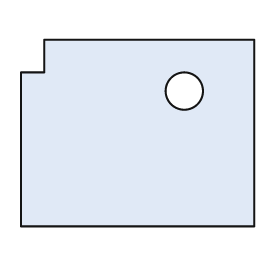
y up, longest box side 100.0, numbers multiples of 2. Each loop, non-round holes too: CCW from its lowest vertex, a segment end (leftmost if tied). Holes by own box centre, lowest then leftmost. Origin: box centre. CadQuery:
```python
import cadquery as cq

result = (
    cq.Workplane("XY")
    .moveTo(-50.0, -40.0)
    .lineTo(50.0, -40.0)
    .lineTo(50.0, 40.0)
    .lineTo(-40.0, 40.0)
    .lineTo(-40.0, 26.0)
    .lineTo(-50.0, 26.0)
    .close()
    .moveTo(20.0, 18.0)
    .circle(8.0)
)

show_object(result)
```